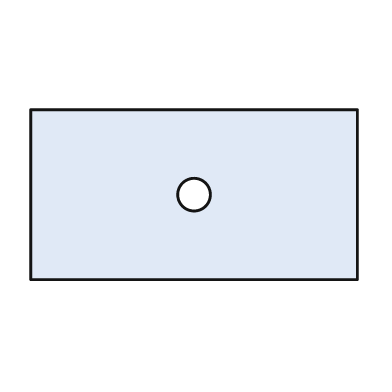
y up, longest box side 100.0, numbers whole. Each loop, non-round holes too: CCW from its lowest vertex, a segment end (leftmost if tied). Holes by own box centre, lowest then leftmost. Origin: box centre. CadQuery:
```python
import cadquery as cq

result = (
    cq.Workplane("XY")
    .moveTo(-50.0, -26.0)
    .lineTo(50.0, -26.0)
    .lineTo(50.0, 26.0)
    .lineTo(-50.0, 26.0)
    .close()
    .moveTo(0.0, 0.0)
    .circle(5.0)
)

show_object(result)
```